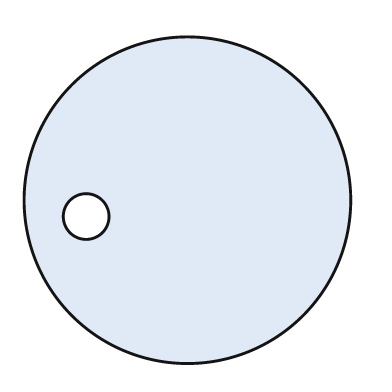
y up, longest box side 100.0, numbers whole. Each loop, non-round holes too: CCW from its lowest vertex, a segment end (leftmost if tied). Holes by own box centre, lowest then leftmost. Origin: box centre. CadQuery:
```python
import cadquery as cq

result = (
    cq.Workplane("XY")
    .moveTo(0.0, 0.0)
    .circle(50.0)
    .moveTo(-31.0, -5.0)
    .circle(7.0)
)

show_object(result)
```